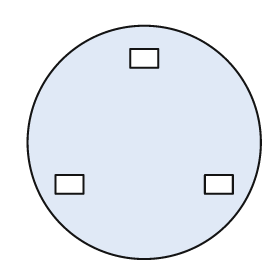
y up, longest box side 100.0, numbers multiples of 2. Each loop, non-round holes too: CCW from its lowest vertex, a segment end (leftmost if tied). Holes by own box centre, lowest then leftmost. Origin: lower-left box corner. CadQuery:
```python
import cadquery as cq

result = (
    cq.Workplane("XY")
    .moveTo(50.0, 50.0)
    .circle(50.0)
    .moveTo(12.0, 28.0)
    .lineTo(24.0, 28.0)
    .lineTo(24.0, 36.0)
    .lineTo(12.0, 36.0)
    .close()
    .moveTo(76.0, 28.0)
    .lineTo(88.0, 28.0)
    .lineTo(88.0, 36.0)
    .lineTo(76.0, 36.0)
    .close()
    .moveTo(44.0, 82.0)
    .lineTo(56.0, 82.0)
    .lineTo(56.0, 90.0)
    .lineTo(44.0, 90.0)
    .close()
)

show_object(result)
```